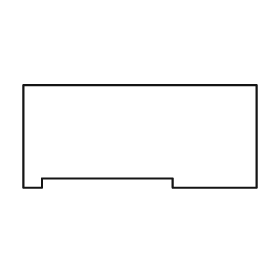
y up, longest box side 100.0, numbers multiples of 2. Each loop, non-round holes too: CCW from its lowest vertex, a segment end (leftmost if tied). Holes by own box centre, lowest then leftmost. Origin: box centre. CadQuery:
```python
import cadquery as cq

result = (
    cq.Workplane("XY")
    .moveTo(-50.0, -22.0)
    .lineTo(-42.0, -22.0)
    .lineTo(-42.0, -18.0)
    .lineTo(14.0, -18.0)
    .lineTo(14.0, -22.0)
    .lineTo(50.0, -22.0)
    .lineTo(50.0, 22.0)
    .lineTo(-50.0, 22.0)
    .close()
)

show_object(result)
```